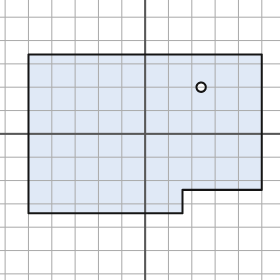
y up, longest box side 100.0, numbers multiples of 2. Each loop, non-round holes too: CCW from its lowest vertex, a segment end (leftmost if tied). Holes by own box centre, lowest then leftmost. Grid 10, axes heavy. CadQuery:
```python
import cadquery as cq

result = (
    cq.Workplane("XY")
    .moveTo(-50.0, -34.0)
    .lineTo(16.0, -34.0)
    .lineTo(16.0, -24.0)
    .lineTo(50.0, -24.0)
    .lineTo(50.0, 34.0)
    .lineTo(-50.0, 34.0)
    .close()
    .moveTo(24.0, 20.0)
    .circle(2.0)
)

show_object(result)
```